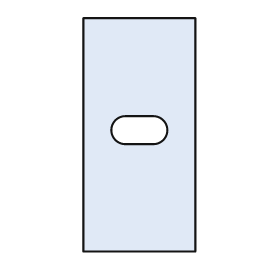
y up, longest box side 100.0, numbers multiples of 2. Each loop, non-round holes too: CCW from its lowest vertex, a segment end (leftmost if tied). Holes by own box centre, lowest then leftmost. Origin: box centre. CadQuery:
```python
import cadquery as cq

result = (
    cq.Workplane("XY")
    .moveTo(-24.0, -50.0)
    .lineTo(24.0, -50.0)
    .lineTo(24.0, 50.0)
    .lineTo(-24.0, 50.0)
    .close()
    .moveTo(-6.0, -4.0)
    .lineTo(6.0, -4.0)
    .threePointArc((12.0, 2.0), (6.0, 8.0))
    .lineTo(-6.0, 8.0)
    .threePointArc((-12.0, 2.0), (-6.0, -4.0))
    .close()
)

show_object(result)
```